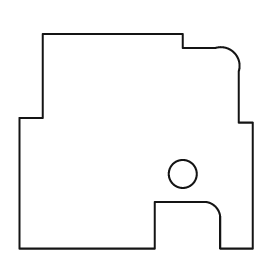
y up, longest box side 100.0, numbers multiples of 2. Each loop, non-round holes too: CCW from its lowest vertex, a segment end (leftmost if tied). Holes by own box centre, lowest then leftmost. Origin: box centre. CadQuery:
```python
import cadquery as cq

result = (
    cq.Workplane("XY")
    .moveTo(-50.0, -46.0)
    .lineTo(8.0, -46.0)
    .lineTo(8.0, -26.0)
    .lineTo(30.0, -26.0)
    .threePointArc((34.0, -28.0), (36.0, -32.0))
    .lineTo(36.0, -46.0)
    .lineTo(50.0, -46.0)
    .lineTo(50.0, 8.0)
    .lineTo(44.0, 8.0)
    .lineTo(44.0, 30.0)
    .threePointArc((42.0, 38.0), (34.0, 40.0))
    .lineTo(20.0, 40.0)
    .lineTo(20.0, 46.0)
    .lineTo(-40.0, 46.0)
    .lineTo(-40.0, 10.0)
    .lineTo(-50.0, 10.0)
    .close()
    .moveTo(20.0, -14.0)
    .circle(6.0)
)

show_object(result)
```